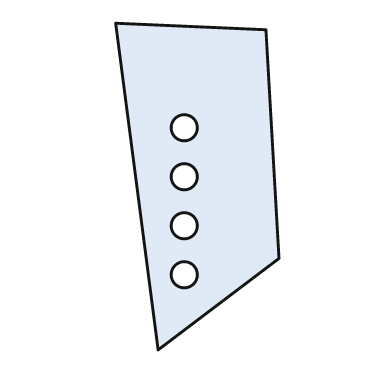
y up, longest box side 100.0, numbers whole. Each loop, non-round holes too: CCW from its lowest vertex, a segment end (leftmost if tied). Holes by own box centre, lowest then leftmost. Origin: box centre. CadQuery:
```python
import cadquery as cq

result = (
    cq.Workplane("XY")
    .moveTo(-12.0, -50.0)
    .lineTo(25.0, -22.0)
    .lineTo(21.0, 48.0)
    .lineTo(-25.0, 50.0)
    .close()
    .moveTo(-4.0, -27.0)
    .circle(4.0)
    .moveTo(-4.0, -12.0)
    .circle(4.0)
    .moveTo(-4.0, 3.0)
    .circle(4.0)
    .moveTo(-4.0, 18.0)
    .circle(4.0)
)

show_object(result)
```